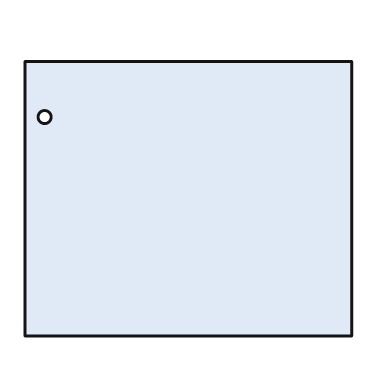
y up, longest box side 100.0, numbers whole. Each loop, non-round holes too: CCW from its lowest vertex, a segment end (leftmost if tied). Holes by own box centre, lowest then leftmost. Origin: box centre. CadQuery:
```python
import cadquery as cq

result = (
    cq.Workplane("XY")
    .moveTo(-50.0, -42.0)
    .lineTo(50.0, -42.0)
    .lineTo(50.0, 42.0)
    .lineTo(-50.0, 42.0)
    .close()
    .moveTo(-44.0, 25.0)
    .circle(2.0)
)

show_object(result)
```